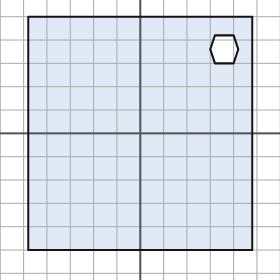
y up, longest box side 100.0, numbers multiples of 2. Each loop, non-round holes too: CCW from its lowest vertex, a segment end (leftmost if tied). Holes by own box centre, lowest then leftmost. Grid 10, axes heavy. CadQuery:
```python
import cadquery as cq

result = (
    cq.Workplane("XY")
    .moveTo(-48.0, -50.0)
    .lineTo(48.0, -50.0)
    .lineTo(48.0, 50.0)
    .lineTo(-48.0, 50.0)
    .close()
    .moveTo(32.0, 30.0)
    .lineTo(40.0, 30.0)
    .lineTo(42.0, 36.0)
    .lineTo(40.0, 42.0)
    .lineTo(32.0, 42.0)
    .lineTo(30.0, 36.0)
    .close()
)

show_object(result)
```